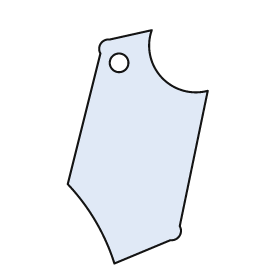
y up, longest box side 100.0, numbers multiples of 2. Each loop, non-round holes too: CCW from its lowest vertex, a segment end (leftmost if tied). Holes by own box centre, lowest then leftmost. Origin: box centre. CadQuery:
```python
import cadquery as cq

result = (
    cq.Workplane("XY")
    .moveTo(-10.0, -50.0)
    .lineTo(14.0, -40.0)
    .threePointArc((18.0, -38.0), (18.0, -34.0))
    .lineTo(30.0, 24.0)
    .threePointArc((10.0, 30.0), (6.0, 50.0))
    .lineTo(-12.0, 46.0)
    .threePointArc((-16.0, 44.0), (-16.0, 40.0))
    .lineTo(-30.0, -16.0)
    .threePointArc((-18.0, -32.0), (-10.0, -50.0))
    .close()
    .moveTo(-8.0, 36.0)
    .circle(4.0)
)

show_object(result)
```